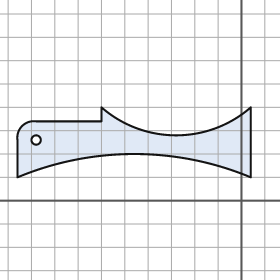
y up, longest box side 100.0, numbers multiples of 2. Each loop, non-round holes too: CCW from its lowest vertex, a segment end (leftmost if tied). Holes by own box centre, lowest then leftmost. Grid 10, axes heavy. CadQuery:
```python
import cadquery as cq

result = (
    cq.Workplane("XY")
    .moveTo(-96.0, 10.0)
    .threePointArc((-46.0, 20.0), (4.0, 10.0))
    .lineTo(4.0, 40.0)
    .threePointArc((-28.0, 28.0), (-60.0, 40.0))
    .lineTo(-60.0, 34.0)
    .lineTo(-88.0, 34.0)
    .threePointArc((-94.0, 32.0), (-96.0, 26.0))
    .close()
    .moveTo(-88.0, 26.0)
    .circle(2.0)
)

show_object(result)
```